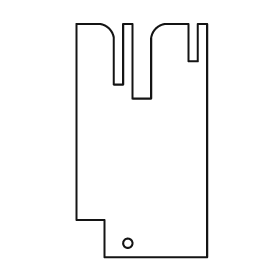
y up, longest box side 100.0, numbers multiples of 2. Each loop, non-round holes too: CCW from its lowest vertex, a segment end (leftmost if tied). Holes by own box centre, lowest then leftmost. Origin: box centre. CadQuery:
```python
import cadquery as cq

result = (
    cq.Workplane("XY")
    .moveTo(-16.0, -50.0)
    .lineTo(28.0, -50.0)
    .lineTo(28.0, 50.0)
    .lineTo(24.0, 50.0)
    .lineTo(24.0, 34.0)
    .lineTo(20.0, 34.0)
    .lineTo(20.0, 50.0)
    .lineTo(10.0, 50.0)
    .threePointArc((6.0, 48.0), (4.0, 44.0))
    .lineTo(4.0, 18.0)
    .lineTo(-4.0, 18.0)
    .lineTo(-4.0, 50.0)
    .lineTo(-8.0, 50.0)
    .lineTo(-8.0, 24.0)
    .lineTo(-12.0, 24.0)
    .lineTo(-12.0, 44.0)
    .threePointArc((-14.0, 48.0), (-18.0, 50.0))
    .lineTo(-28.0, 50.0)
    .lineTo(-28.0, -34.0)
    .lineTo(-16.0, -34.0)
    .close()
    .moveTo(-6.0, -44.0)
    .circle(2.0)
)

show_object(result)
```